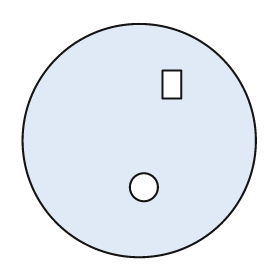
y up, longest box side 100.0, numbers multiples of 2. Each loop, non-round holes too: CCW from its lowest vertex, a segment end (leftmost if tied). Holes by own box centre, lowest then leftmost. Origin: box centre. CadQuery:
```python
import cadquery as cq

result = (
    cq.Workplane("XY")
    .moveTo(0.0, 0.0)
    .circle(50.0)
    .moveTo(2.0, -20.0)
    .circle(6.0)
    .moveTo(10.0, 18.0)
    .lineTo(18.0, 18.0)
    .lineTo(18.0, 30.0)
    .lineTo(10.0, 30.0)
    .close()
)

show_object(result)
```